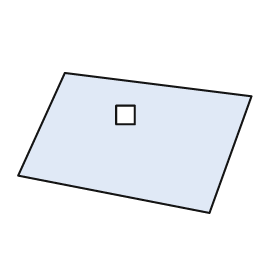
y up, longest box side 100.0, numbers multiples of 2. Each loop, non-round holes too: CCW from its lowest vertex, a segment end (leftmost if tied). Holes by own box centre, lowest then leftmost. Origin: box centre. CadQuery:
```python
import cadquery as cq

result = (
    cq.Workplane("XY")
    .moveTo(32.0, -30.0)
    .lineTo(50.0, 20.0)
    .lineTo(-30.0, 30.0)
    .lineTo(-50.0, -14.0)
    .close()
    .moveTo(-8.0, 8.0)
    .lineTo(0.0, 8.0)
    .lineTo(0.0, 16.0)
    .lineTo(-8.0, 16.0)
    .close()
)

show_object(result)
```